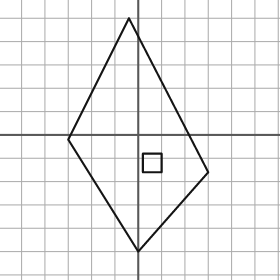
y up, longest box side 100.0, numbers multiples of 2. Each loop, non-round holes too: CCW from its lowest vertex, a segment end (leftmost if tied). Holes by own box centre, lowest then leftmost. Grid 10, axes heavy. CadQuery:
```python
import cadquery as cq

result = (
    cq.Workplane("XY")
    .moveTo(0.0, -50.0)
    .lineTo(30.0, -16.0)
    .lineTo(-4.0, 50.0)
    .lineTo(-30.0, -2.0)
    .close()
    .moveTo(2.0, -16.0)
    .lineTo(10.0, -16.0)
    .lineTo(10.0, -8.0)
    .lineTo(2.0, -8.0)
    .close()
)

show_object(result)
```